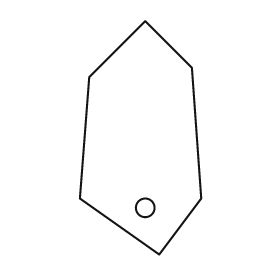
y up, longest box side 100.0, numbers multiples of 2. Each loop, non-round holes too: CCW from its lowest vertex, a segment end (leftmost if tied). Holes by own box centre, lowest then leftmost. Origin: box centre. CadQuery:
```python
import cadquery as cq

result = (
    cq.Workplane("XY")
    .moveTo(8.0, -50.0)
    .lineTo(26.0, -26.0)
    .lineTo(22.0, 30.0)
    .lineTo(2.0, 50.0)
    .lineTo(-22.0, 26.0)
    .lineTo(-26.0, -26.0)
    .close()
    .moveTo(2.0, -30.0)
    .circle(4.0)
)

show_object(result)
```